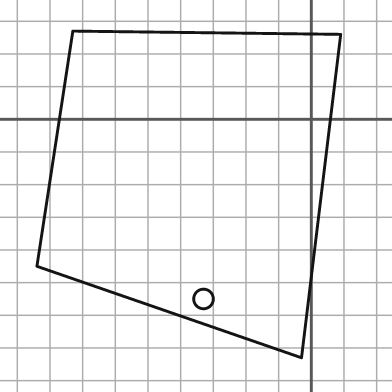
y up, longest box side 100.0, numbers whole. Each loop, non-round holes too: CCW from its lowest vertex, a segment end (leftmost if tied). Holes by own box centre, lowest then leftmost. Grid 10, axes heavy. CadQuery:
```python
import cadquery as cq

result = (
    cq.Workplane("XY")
    .moveTo(-3.0, -73.0)
    .lineTo(9.0, 26.0)
    .lineTo(-73.0, 27.0)
    .lineTo(-84.0, -45.0)
    .close()
    .moveTo(-33.0, -55.0)
    .circle(3.0)
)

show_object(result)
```